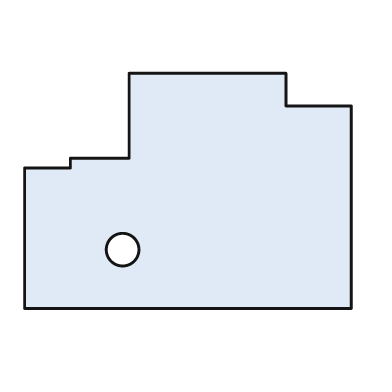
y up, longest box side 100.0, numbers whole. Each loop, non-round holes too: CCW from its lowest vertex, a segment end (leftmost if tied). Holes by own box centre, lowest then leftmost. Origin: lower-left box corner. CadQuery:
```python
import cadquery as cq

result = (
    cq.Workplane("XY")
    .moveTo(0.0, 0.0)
    .lineTo(100.0, 0.0)
    .lineTo(100.0, 62.0)
    .lineTo(80.0, 62.0)
    .lineTo(80.0, 72.0)
    .lineTo(32.0, 72.0)
    .lineTo(32.0, 46.0)
    .lineTo(14.0, 46.0)
    .lineTo(14.0, 43.0)
    .lineTo(0.0, 43.0)
    .close()
    .moveTo(30.0, 18.0)
    .circle(5.0)
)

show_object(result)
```